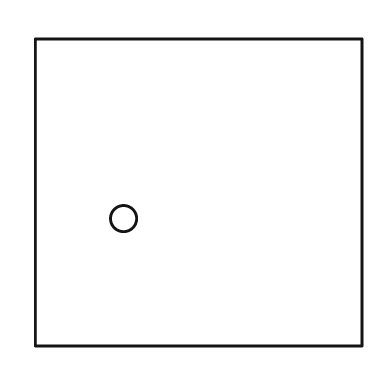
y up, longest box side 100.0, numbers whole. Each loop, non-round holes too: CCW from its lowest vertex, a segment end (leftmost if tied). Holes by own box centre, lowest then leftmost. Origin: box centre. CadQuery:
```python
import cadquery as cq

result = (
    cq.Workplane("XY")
    .moveTo(-50.0, -47.0)
    .lineTo(50.0, -47.0)
    .lineTo(50.0, 47.0)
    .lineTo(-50.0, 47.0)
    .close()
    .moveTo(-23.0, -8.0)
    .circle(4.0)
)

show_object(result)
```